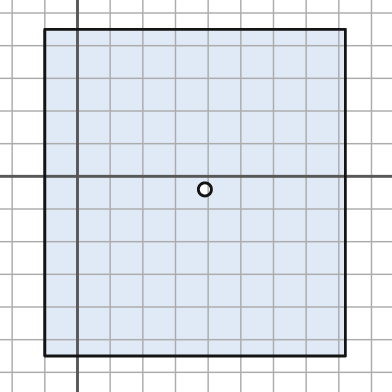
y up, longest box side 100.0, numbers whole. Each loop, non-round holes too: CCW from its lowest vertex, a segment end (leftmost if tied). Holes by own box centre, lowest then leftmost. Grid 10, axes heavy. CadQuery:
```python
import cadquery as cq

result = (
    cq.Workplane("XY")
    .moveTo(-10.0, -55.0)
    .lineTo(82.0, -55.0)
    .lineTo(82.0, 45.0)
    .lineTo(-10.0, 45.0)
    .close()
    .moveTo(39.0, -4.0)
    .circle(2.0)
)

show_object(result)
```